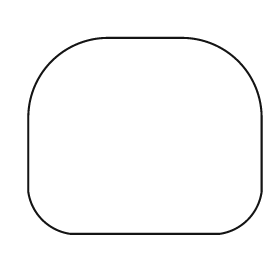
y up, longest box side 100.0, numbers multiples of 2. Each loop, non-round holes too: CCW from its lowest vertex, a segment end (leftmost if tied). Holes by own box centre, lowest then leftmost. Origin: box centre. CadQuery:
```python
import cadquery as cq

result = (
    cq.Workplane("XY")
    .moveTo(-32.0, -42.0)
    .lineTo(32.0, -42.0)
    .threePointArc((44.0, -36.0), (50.0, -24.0))
    .lineTo(50.0, 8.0)
    .threePointArc((40.0, 32.0), (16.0, 42.0))
    .lineTo(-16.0, 42.0)
    .threePointArc((-40.0, 32.0), (-50.0, 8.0))
    .lineTo(-50.0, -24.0)
    .threePointArc((-44.0, -36.0), (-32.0, -42.0))
    .close()
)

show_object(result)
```